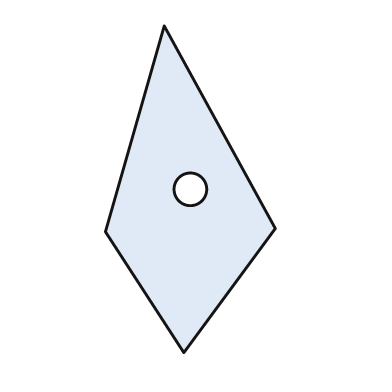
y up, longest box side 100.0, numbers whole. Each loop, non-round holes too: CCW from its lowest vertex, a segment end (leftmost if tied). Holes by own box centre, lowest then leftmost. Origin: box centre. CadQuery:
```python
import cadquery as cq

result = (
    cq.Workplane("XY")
    .moveTo(-2.0, -50.0)
    .lineTo(26.0, -12.0)
    .lineTo(-8.0, 50.0)
    .lineTo(-26.0, -13.0)
    .close()
    .moveTo(0.0, 0.0)
    .circle(5.0)
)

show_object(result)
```